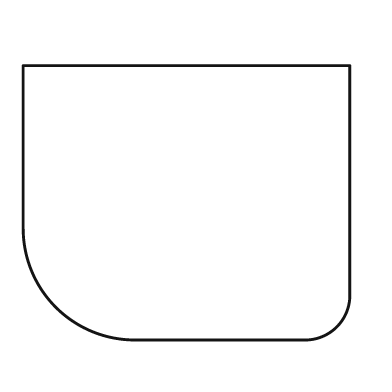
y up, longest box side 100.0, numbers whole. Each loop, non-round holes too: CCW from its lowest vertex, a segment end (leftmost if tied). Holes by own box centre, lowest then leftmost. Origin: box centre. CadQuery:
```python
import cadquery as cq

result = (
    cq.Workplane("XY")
    .moveTo(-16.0, -42.0)
    .lineTo(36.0, -42.0)
    .threePointArc((46.0, -38.0), (50.0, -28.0))
    .lineTo(50.0, 42.0)
    .lineTo(-50.0, 42.0)
    .lineTo(-50.0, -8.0)
    .threePointArc((-40.0, -32.0), (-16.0, -42.0))
    .close()
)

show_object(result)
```